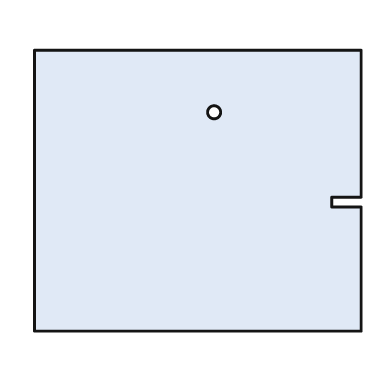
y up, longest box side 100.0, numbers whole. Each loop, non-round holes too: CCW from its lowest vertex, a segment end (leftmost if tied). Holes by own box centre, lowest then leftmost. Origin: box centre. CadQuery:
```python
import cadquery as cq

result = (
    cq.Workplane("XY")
    .moveTo(-50.0, -43.0)
    .lineTo(50.0, -43.0)
    .lineTo(50.0, -5.0)
    .lineTo(41.0, -5.0)
    .lineTo(41.0, -2.0)
    .lineTo(50.0, -2.0)
    .lineTo(50.0, 43.0)
    .lineTo(-50.0, 43.0)
    .close()
    .moveTo(5.0, 24.0)
    .circle(2.0)
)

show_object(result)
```